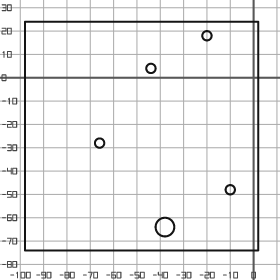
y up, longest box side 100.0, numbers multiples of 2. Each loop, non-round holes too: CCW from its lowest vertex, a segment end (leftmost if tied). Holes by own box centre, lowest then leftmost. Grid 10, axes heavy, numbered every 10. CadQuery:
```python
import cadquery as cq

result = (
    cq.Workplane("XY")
    .moveTo(-98.0, -74.0)
    .lineTo(2.0, -74.0)
    .lineTo(2.0, 24.0)
    .lineTo(-98.0, 24.0)
    .close()
    .moveTo(-38.0, -64.0)
    .circle(4.0)
    .moveTo(-10.0, -48.0)
    .circle(2.0)
    .moveTo(-66.0, -28.0)
    .circle(2.0)
    .moveTo(-44.0, 4.0)
    .circle(2.0)
    .moveTo(-20.0, 18.0)
    .circle(2.0)
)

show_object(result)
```